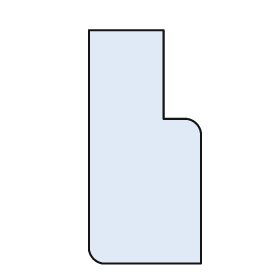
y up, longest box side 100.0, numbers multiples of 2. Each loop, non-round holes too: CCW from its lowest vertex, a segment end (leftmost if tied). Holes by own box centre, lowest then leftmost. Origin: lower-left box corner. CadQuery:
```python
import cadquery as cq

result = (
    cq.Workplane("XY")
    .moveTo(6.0, 0.0)
    .lineTo(48.0, 0.0)
    .lineTo(48.0, 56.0)
    .threePointArc((46.0, 60.0), (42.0, 62.0))
    .lineTo(32.0, 62.0)
    .lineTo(32.0, 100.0)
    .lineTo(0.0, 100.0)
    .lineTo(0.0, 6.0)
    .threePointArc((2.0, 2.0), (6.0, 0.0))
    .close()
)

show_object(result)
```